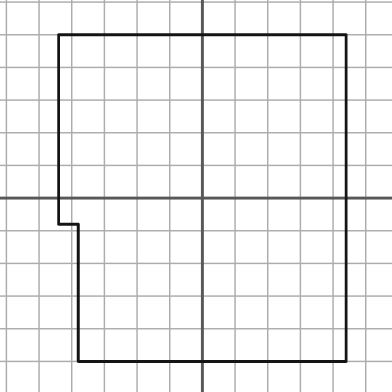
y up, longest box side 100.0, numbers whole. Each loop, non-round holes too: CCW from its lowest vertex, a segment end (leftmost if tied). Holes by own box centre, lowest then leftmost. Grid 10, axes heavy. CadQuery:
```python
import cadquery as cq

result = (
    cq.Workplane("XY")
    .moveTo(-38.0, -50.0)
    .lineTo(44.0, -50.0)
    .lineTo(44.0, 50.0)
    .lineTo(-44.0, 50.0)
    .lineTo(-44.0, -8.0)
    .lineTo(-38.0, -8.0)
    .close()
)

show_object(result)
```